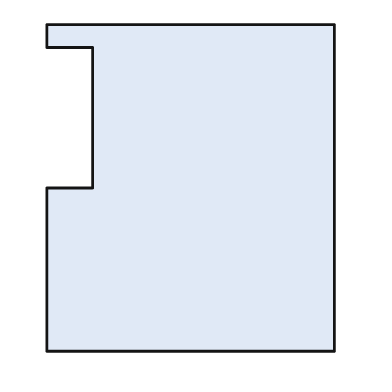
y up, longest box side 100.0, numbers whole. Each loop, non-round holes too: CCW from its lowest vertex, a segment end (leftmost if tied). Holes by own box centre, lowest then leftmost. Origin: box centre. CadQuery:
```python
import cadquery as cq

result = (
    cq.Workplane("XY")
    .moveTo(-44.0, -50.0)
    .lineTo(44.0, -50.0)
    .lineTo(44.0, 50.0)
    .lineTo(-44.0, 50.0)
    .lineTo(-44.0, 43.0)
    .lineTo(-30.0, 43.0)
    .lineTo(-30.0, 0.0)
    .lineTo(-44.0, 0.0)
    .close()
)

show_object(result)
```